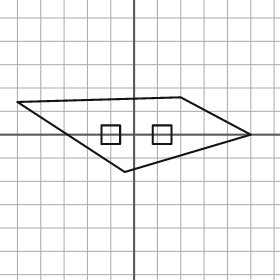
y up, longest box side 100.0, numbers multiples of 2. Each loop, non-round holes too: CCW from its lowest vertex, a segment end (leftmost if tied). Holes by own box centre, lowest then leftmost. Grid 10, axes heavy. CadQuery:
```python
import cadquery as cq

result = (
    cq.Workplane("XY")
    .moveTo(-4.0, -16.0)
    .lineTo(50.0, 0.0)
    .lineTo(20.0, 16.0)
    .lineTo(-50.0, 14.0)
    .close()
    .moveTo(-14.0, -4.0)
    .lineTo(-6.0, -4.0)
    .lineTo(-6.0, 4.0)
    .lineTo(-14.0, 4.0)
    .close()
    .moveTo(8.0, -4.0)
    .lineTo(16.0, -4.0)
    .lineTo(16.0, 4.0)
    .lineTo(8.0, 4.0)
    .close()
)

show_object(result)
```